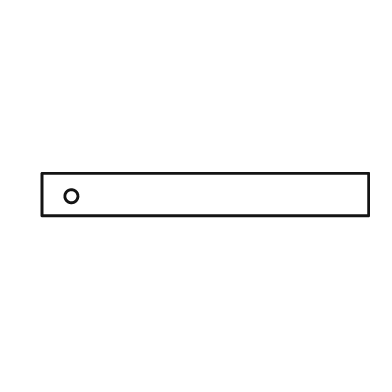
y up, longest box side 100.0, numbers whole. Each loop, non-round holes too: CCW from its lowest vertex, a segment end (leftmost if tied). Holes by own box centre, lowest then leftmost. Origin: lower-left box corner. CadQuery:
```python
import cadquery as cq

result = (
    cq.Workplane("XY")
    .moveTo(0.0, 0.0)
    .lineTo(100.0, 0.0)
    .lineTo(100.0, 13.0)
    .lineTo(0.0, 13.0)
    .close()
    .moveTo(9.0, 6.0)
    .circle(2.0)
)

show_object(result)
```